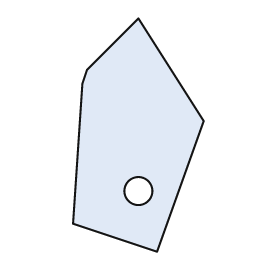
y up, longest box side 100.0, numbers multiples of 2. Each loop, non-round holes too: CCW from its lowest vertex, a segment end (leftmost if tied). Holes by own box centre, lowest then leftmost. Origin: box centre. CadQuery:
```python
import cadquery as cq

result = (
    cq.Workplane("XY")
    .moveTo(8.0, -50.0)
    .lineTo(28.0, 6.0)
    .lineTo(0.0, 50.0)
    .lineTo(-22.0, 28.0)
    .lineTo(-24.0, 22.0)
    .lineTo(-28.0, -38.0)
    .close()
    .moveTo(0.0, -24.0)
    .circle(6.0)
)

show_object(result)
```